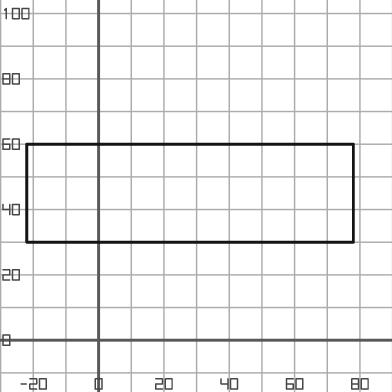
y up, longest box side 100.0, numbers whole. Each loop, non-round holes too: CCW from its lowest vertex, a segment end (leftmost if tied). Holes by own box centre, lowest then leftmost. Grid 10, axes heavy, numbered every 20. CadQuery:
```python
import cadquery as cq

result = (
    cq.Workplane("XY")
    .moveTo(-22.0, 30.0)
    .lineTo(78.0, 30.0)
    .lineTo(78.0, 60.0)
    .lineTo(-22.0, 60.0)
    .close()
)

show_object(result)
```